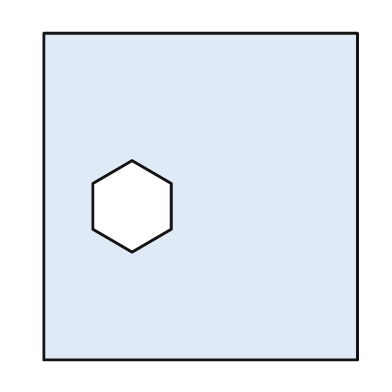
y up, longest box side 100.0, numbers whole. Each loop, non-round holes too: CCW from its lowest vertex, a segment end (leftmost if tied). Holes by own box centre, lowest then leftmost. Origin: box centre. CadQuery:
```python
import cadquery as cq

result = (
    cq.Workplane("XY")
    .moveTo(-48.0, -50.0)
    .lineTo(48.0, -50.0)
    .lineTo(48.0, 50.0)
    .lineTo(-48.0, 50.0)
    .close()
    .moveTo(-21.0, -17.0)
    .lineTo(-9.0, -10.0)
    .lineTo(-9.0, 4.0)
    .lineTo(-21.0, 11.0)
    .lineTo(-33.0, 4.0)
    .lineTo(-33.0, -10.0)
    .close()
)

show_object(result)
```